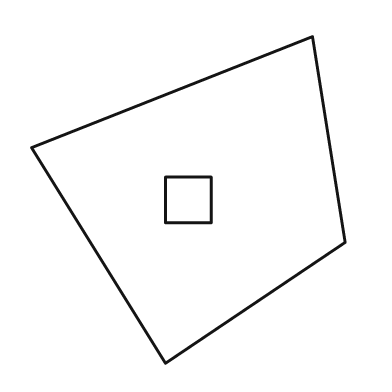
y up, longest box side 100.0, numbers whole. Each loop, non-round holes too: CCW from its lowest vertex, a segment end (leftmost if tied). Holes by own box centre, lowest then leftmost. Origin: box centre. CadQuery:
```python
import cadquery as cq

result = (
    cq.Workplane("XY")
    .moveTo(-7.0, -50.0)
    .lineTo(48.0, -13.0)
    .lineTo(38.0, 50.0)
    .lineTo(-48.0, 16.0)
    .close()
    .moveTo(-7.0, -7.0)
    .lineTo(7.0, -7.0)
    .lineTo(7.0, 7.0)
    .lineTo(-7.0, 7.0)
    .close()
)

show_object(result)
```